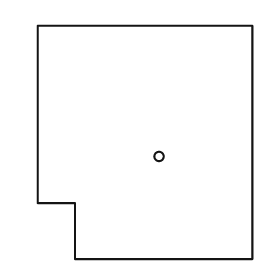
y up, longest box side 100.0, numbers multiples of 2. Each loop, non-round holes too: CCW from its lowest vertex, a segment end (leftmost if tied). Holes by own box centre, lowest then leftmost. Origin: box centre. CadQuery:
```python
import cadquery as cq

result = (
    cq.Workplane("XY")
    .moveTo(-30.0, -50.0)
    .lineTo(46.0, -50.0)
    .lineTo(46.0, 50.0)
    .lineTo(-46.0, 50.0)
    .lineTo(-46.0, -26.0)
    .lineTo(-30.0, -26.0)
    .close()
    .moveTo(6.0, -6.0)
    .circle(2.0)
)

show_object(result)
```